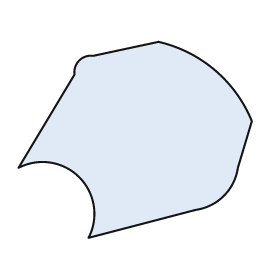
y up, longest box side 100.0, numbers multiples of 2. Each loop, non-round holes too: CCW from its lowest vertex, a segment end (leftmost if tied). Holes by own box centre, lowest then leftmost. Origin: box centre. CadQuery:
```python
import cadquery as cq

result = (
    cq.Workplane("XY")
    .moveTo(-20.0, -42.0)
    .lineTo(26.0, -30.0)
    .threePointArc((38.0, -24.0), (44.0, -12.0))
    .lineTo(50.0, 8.0)
    .threePointArc((34.0, 30.0), (10.0, 42.0))
    .lineTo(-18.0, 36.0)
    .threePointArc((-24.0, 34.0), (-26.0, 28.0))
    .lineTo(-50.0, -12.0)
    .threePointArc((-24.0, -16.0), (-20.0, -42.0))
    .close()
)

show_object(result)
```